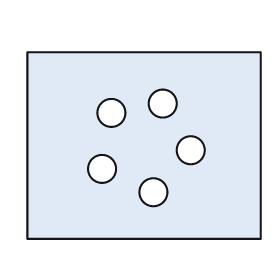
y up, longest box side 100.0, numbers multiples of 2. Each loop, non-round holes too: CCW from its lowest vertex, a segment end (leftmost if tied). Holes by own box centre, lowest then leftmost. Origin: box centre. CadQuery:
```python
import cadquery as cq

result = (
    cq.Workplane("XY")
    .moveTo(-50.0, -40.0)
    .lineTo(50.0, -40.0)
    .lineTo(50.0, 40.0)
    .lineTo(-50.0, 40.0)
    .close()
    .moveTo(4.0, -20.0)
    .circle(6.0)
    .moveTo(-18.0, -10.0)
    .circle(6.0)
    .moveTo(20.0, -2.0)
    .circle(6.0)
    .moveTo(-14.0, 14.0)
    .circle(6.0)
    .moveTo(8.0, 18.0)
    .circle(6.0)
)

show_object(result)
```